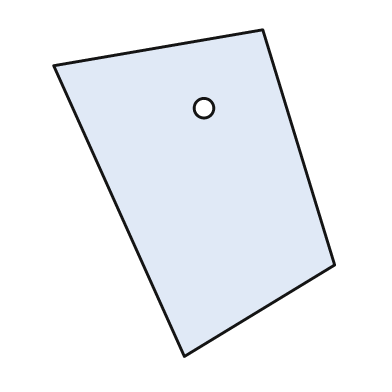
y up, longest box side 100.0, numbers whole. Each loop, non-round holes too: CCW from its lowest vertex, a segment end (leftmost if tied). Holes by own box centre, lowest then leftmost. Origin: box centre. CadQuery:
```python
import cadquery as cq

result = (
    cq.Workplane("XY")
    .moveTo(-3.0, -50.0)
    .lineTo(43.0, -22.0)
    .lineTo(21.0, 50.0)
    .lineTo(-43.0, 39.0)
    .close()
    .moveTo(3.0, 26.0)
    .circle(3.0)
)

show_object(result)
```